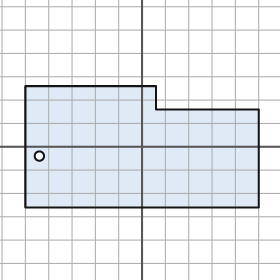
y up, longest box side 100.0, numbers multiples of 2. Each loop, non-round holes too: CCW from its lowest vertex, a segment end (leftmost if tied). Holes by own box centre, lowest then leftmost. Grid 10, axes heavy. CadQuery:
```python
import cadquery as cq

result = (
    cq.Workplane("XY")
    .moveTo(-50.0, -26.0)
    .lineTo(50.0, -26.0)
    .lineTo(50.0, 16.0)
    .lineTo(6.0, 16.0)
    .lineTo(6.0, 26.0)
    .lineTo(-50.0, 26.0)
    .close()
    .moveTo(-44.0, -4.0)
    .circle(2.0)
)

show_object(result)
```